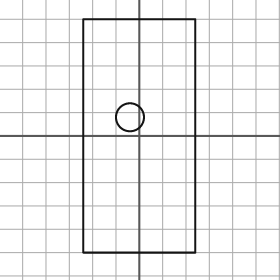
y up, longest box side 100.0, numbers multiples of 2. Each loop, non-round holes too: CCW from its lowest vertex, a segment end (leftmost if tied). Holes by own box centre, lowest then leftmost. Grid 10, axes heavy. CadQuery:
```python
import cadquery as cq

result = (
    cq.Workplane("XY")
    .moveTo(-24.0, -50.0)
    .lineTo(24.0, -50.0)
    .lineTo(24.0, 50.0)
    .lineTo(-24.0, 50.0)
    .close()
    .moveTo(-4.0, 8.0)
    .circle(6.0)
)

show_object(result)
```